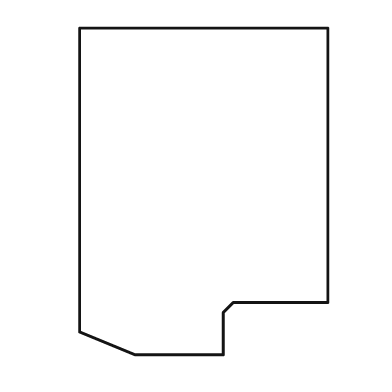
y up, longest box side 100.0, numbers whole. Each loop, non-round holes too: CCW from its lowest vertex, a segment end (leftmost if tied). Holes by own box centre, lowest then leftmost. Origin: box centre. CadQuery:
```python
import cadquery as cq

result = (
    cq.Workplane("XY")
    .moveTo(-21.0, -50.0)
    .lineTo(6.0, -50.0)
    .lineTo(6.0, -37.0)
    .lineTo(9.0, -34.0)
    .lineTo(38.0, -34.0)
    .lineTo(38.0, 50.0)
    .lineTo(-38.0, 50.0)
    .lineTo(-38.0, -43.0)
    .close()
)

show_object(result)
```